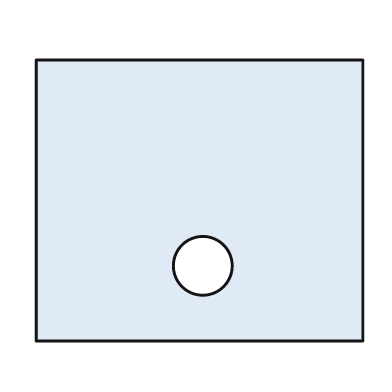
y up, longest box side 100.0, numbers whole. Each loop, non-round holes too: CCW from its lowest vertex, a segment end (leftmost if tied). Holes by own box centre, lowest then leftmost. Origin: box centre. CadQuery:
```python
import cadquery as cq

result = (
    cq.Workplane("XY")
    .moveTo(-50.0, -43.0)
    .lineTo(50.0, -43.0)
    .lineTo(50.0, 43.0)
    .lineTo(-50.0, 43.0)
    .close()
    .moveTo(1.0, -20.0)
    .circle(9.0)
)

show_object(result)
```